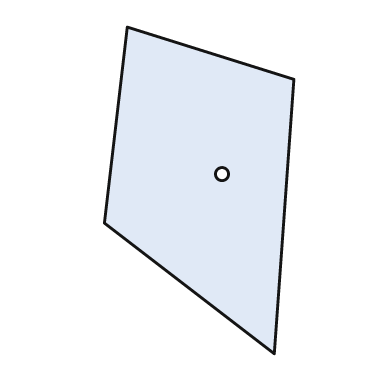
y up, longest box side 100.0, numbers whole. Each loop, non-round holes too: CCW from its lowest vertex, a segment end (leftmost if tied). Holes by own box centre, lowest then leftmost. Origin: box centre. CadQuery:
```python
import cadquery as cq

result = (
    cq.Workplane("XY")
    .moveTo(23.0, -50.0)
    .lineTo(29.0, 34.0)
    .lineTo(-22.0, 50.0)
    .lineTo(-29.0, -10.0)
    .close()
    .moveTo(7.0, 5.0)
    .circle(2.0)
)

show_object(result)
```